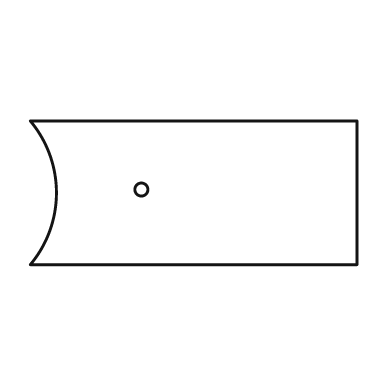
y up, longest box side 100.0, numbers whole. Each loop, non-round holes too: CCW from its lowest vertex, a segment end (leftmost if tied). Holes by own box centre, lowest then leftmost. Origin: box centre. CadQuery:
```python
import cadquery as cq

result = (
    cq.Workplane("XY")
    .moveTo(-50.0, -22.0)
    .lineTo(50.0, -22.0)
    .lineTo(50.0, 22.0)
    .lineTo(-50.0, 22.0)
    .threePointArc((-42.0, 0.0), (-50.0, -22.0))
    .close()
    .moveTo(-16.0, 1.0)
    .circle(2.0)
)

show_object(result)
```